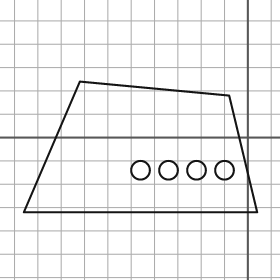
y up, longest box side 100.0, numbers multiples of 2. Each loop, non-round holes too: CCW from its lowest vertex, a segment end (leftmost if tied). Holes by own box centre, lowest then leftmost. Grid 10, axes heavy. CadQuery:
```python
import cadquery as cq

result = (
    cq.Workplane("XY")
    .moveTo(-96.0, -32.0)
    .lineTo(4.0, -32.0)
    .lineTo(-8.0, 18.0)
    .lineTo(-72.0, 24.0)
    .close()
    .moveTo(-46.0, -14.0)
    .circle(4.0)
    .moveTo(-34.0, -14.0)
    .circle(4.0)
    .moveTo(-22.0, -14.0)
    .circle(4.0)
    .moveTo(-10.0, -14.0)
    .circle(4.0)
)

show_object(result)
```